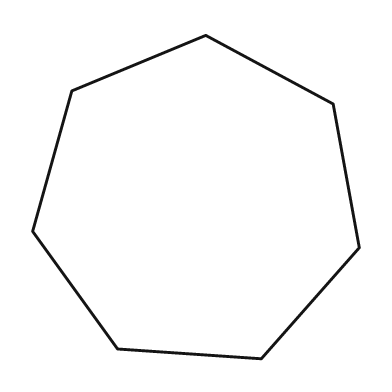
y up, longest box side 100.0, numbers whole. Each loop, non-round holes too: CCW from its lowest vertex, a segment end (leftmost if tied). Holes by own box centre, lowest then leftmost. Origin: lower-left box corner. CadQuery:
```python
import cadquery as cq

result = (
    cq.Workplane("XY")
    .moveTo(70.0, 0.0)
    .lineTo(100.0, 34.0)
    .lineTo(92.0, 78.0)
    .lineTo(53.0, 99.0)
    .lineTo(12.0, 82.0)
    .lineTo(0.0, 39.0)
    .lineTo(26.0, 3.0)
    .close()
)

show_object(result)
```